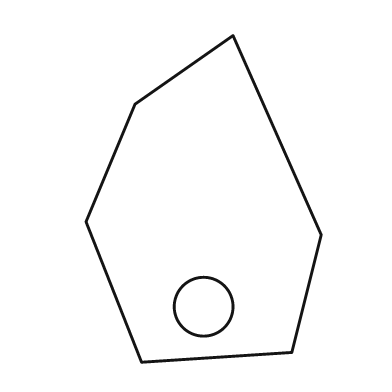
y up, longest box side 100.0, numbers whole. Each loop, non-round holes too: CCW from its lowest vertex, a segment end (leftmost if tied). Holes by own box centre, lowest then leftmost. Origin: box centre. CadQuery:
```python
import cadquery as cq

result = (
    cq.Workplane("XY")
    .moveTo(-19.0, -50.0)
    .lineTo(27.0, -47.0)
    .lineTo(36.0, -11.0)
    .lineTo(9.0, 50.0)
    .lineTo(-21.0, 29.0)
    .lineTo(-36.0, -7.0)
    .close()
    .moveTo(0.0, -33.0)
    .circle(9.0)
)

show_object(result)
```